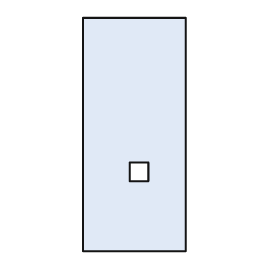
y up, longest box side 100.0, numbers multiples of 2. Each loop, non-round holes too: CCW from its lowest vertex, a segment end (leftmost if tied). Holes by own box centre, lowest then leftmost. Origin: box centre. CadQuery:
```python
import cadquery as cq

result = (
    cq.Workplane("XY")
    .moveTo(-22.0, -50.0)
    .lineTo(22.0, -50.0)
    .lineTo(22.0, 50.0)
    .lineTo(-22.0, 50.0)
    .close()
    .moveTo(-2.0, -20.0)
    .lineTo(6.0, -20.0)
    .lineTo(6.0, -12.0)
    .lineTo(-2.0, -12.0)
    .close()
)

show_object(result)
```